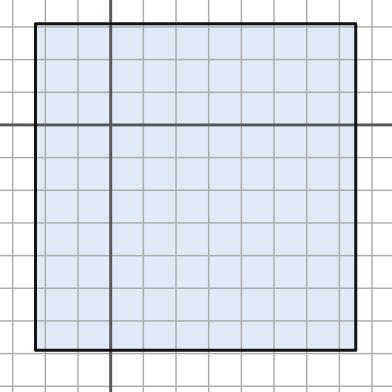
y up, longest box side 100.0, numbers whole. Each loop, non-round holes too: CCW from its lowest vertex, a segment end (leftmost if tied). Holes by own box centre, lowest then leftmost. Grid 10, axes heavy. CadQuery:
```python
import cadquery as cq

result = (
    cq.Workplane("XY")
    .moveTo(-23.0, -69.0)
    .lineTo(75.0, -69.0)
    .lineTo(75.0, 31.0)
    .lineTo(-23.0, 31.0)
    .close()
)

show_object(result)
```